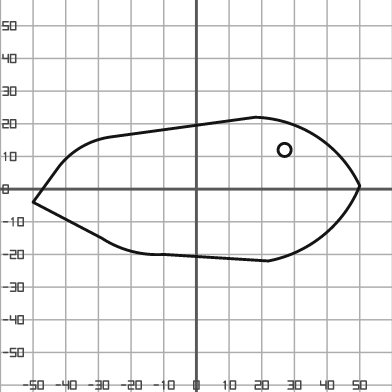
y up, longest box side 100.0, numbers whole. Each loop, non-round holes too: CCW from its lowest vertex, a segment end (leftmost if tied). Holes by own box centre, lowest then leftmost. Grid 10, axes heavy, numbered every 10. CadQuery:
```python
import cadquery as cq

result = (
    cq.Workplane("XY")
    .moveTo(22.0, -22.0)
    .threePointArc((39.0, -14.0), (50.0, 1.0))
    .threePointArc((37.0, 16.0), (18.0, 22.0))
    .lineTo(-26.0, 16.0)
    .threePointArc((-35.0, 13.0), (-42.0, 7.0))
    .lineTo(-50.0, -4.0)
    .lineTo(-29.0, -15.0)
    .threePointArc((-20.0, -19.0), (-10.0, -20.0))
    .close()
    .moveTo(27.0, 12.0)
    .circle(2.0)
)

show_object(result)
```